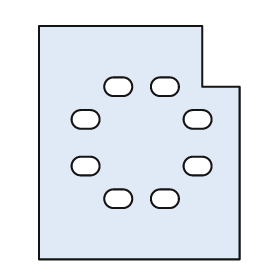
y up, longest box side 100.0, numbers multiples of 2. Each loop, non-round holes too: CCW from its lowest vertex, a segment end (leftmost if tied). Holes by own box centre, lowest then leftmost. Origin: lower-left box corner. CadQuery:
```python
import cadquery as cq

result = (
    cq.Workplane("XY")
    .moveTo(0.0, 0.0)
    .lineTo(86.0, 0.0)
    .lineTo(86.0, 74.0)
    .lineTo(70.0, 74.0)
    .lineTo(70.0, 100.0)
    .lineTo(0.0, 100.0)
    .close()
    .moveTo(32.0, 22.0)
    .lineTo(36.0, 22.0)
    .threePointArc((40.0, 26.0), (36.0, 30.0))
    .lineTo(32.0, 30.0)
    .threePointArc((28.0, 26.0), (32.0, 22.0))
    .close()
    .moveTo(52.0, 22.0)
    .lineTo(56.0, 22.0)
    .threePointArc((60.0, 26.0), (56.0, 30.0))
    .lineTo(52.0, 30.0)
    .threePointArc((48.0, 26.0), (52.0, 22.0))
    .close()
    .moveTo(18.0, 36.0)
    .lineTo(22.0, 36.0)
    .threePointArc((26.0, 40.0), (22.0, 44.0))
    .lineTo(18.0, 44.0)
    .threePointArc((14.0, 40.0), (18.0, 36.0))
    .close()
    .moveTo(66.0, 36.0)
    .lineTo(70.0, 36.0)
    .threePointArc((74.0, 40.0), (70.0, 44.0))
    .lineTo(66.0, 44.0)
    .threePointArc((62.0, 40.0), (66.0, 36.0))
    .close()
    .moveTo(18.0, 56.0)
    .lineTo(22.0, 56.0)
    .threePointArc((26.0, 60.0), (22.0, 64.0))
    .lineTo(18.0, 64.0)
    .threePointArc((14.0, 60.0), (18.0, 56.0))
    .close()
    .moveTo(66.0, 56.0)
    .lineTo(70.0, 56.0)
    .threePointArc((74.0, 60.0), (70.0, 64.0))
    .lineTo(66.0, 64.0)
    .threePointArc((62.0, 60.0), (66.0, 56.0))
    .close()
    .moveTo(32.0, 70.0)
    .lineTo(36.0, 70.0)
    .threePointArc((40.0, 74.0), (36.0, 78.0))
    .lineTo(32.0, 78.0)
    .threePointArc((28.0, 74.0), (32.0, 70.0))
    .close()
    .moveTo(52.0, 70.0)
    .lineTo(56.0, 70.0)
    .threePointArc((60.0, 74.0), (56.0, 78.0))
    .lineTo(52.0, 78.0)
    .threePointArc((48.0, 74.0), (52.0, 70.0))
    .close()
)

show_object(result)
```